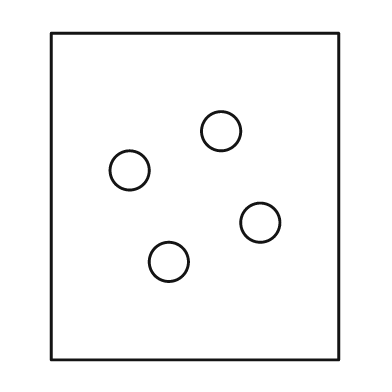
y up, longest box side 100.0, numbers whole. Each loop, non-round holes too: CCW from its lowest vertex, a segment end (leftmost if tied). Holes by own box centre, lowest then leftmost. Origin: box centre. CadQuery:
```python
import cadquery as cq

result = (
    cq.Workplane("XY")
    .moveTo(-44.0, -50.0)
    .lineTo(44.0, -50.0)
    .lineTo(44.0, 50.0)
    .lineTo(-44.0, 50.0)
    .close()
    .moveTo(-8.0, -20.0)
    .circle(6.0)
    .moveTo(20.0, -8.0)
    .circle(6.0)
    .moveTo(-20.0, 8.0)
    .circle(6.0)
    .moveTo(8.0, 20.0)
    .circle(6.0)
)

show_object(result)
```